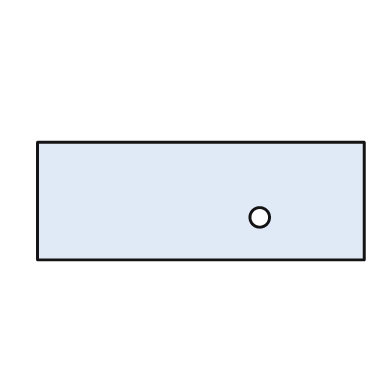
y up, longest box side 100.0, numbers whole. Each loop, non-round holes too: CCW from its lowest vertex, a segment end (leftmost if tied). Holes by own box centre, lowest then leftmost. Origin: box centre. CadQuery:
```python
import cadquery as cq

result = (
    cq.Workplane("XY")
    .moveTo(-50.0, -18.0)
    .lineTo(50.0, -18.0)
    .lineTo(50.0, 18.0)
    .lineTo(-50.0, 18.0)
    .close()
    .moveTo(18.0, -5.0)
    .circle(3.0)
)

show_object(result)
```